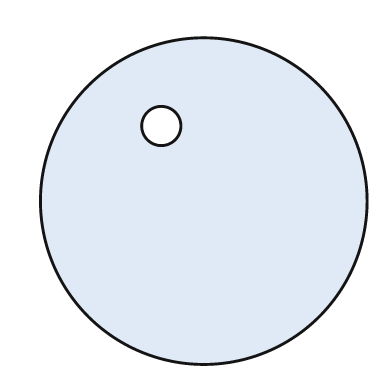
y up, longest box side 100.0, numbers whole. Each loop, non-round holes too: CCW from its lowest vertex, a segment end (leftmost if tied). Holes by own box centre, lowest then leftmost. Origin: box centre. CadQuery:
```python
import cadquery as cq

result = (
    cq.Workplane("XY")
    .moveTo(0.0, 0.0)
    .circle(50.0)
    .moveTo(-13.0, 23.0)
    .circle(6.0)
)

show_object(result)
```